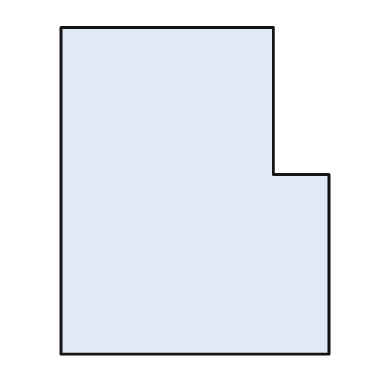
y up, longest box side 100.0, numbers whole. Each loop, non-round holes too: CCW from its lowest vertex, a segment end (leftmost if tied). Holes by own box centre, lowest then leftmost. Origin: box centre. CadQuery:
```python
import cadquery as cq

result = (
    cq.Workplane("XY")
    .moveTo(-41.0, -50.0)
    .lineTo(41.0, -50.0)
    .lineTo(41.0, 5.0)
    .lineTo(24.0, 5.0)
    .lineTo(24.0, 50.0)
    .lineTo(-41.0, 50.0)
    .close()
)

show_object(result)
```